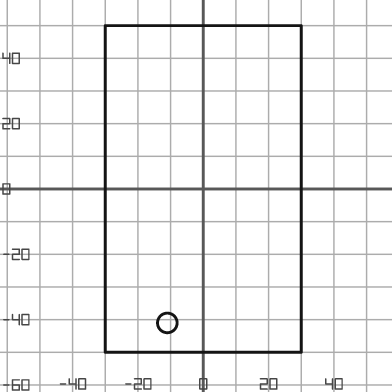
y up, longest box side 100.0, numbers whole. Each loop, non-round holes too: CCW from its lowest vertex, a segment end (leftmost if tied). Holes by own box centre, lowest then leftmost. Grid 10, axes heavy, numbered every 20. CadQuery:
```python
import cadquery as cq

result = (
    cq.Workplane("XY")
    .moveTo(-30.0, -50.0)
    .lineTo(30.0, -50.0)
    .lineTo(30.0, 50.0)
    .lineTo(-30.0, 50.0)
    .close()
    .moveTo(-11.0, -41.0)
    .circle(3.0)
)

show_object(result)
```